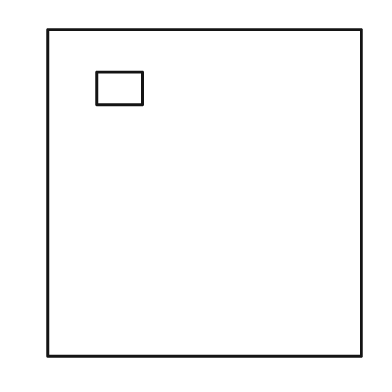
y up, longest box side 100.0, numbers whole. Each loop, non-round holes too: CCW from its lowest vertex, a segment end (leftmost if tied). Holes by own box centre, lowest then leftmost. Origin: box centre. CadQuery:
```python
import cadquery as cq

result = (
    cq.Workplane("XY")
    .moveTo(-48.0, -50.0)
    .lineTo(48.0, -50.0)
    .lineTo(48.0, 50.0)
    .lineTo(-48.0, 50.0)
    .close()
    .moveTo(-33.0, 27.0)
    .lineTo(-19.0, 27.0)
    .lineTo(-19.0, 37.0)
    .lineTo(-33.0, 37.0)
    .close()
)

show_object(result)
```